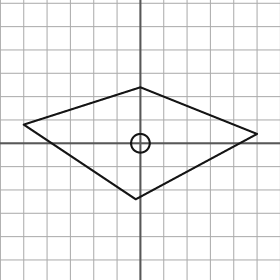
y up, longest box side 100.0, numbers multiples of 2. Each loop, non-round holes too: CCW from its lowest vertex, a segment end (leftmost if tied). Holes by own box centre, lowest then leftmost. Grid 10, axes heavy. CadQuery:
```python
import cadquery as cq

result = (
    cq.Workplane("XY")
    .moveTo(-2.0, -24.0)
    .lineTo(50.0, 4.0)
    .lineTo(0.0, 24.0)
    .lineTo(-50.0, 8.0)
    .close()
    .moveTo(0.0, 0.0)
    .circle(4.0)
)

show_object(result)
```